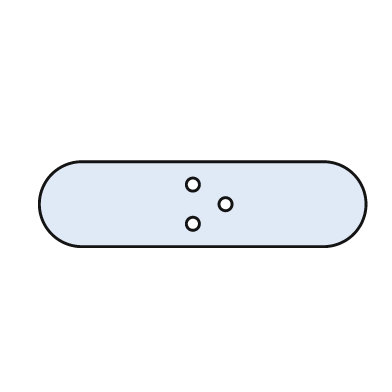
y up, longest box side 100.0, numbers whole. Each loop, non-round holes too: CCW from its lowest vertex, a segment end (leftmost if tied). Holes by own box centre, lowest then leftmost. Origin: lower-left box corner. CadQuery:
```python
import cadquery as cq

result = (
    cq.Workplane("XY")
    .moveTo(13.0, 0.0)
    .lineTo(87.0, 0.0)
    .threePointArc((100.0, 13.0), (87.0, 26.0))
    .lineTo(13.0, 26.0)
    .threePointArc((0.0, 13.0), (13.0, 0.0))
    .close()
    .moveTo(47.0, 7.0)
    .circle(2.0)
    .moveTo(57.0, 13.0)
    .circle(2.0)
    .moveTo(47.0, 19.0)
    .circle(2.0)
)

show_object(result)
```